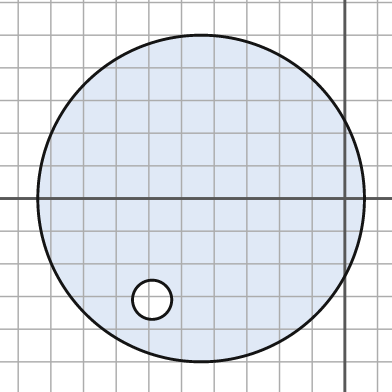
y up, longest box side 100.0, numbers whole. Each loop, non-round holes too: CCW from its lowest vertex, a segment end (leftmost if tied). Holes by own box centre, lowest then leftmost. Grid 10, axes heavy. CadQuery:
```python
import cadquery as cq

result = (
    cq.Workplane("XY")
    .moveTo(-44.0, 0.0)
    .circle(50.0)
    .moveTo(-59.0, -31.0)
    .circle(6.0)
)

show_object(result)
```